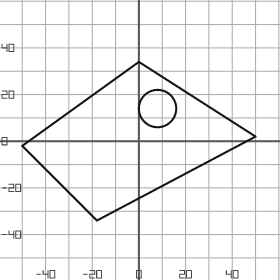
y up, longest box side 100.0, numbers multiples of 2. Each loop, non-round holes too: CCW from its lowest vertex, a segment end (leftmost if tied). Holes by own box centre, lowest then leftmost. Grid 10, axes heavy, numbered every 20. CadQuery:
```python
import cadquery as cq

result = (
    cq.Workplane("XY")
    .moveTo(-18.0, -34.0)
    .lineTo(50.0, 2.0)
    .lineTo(0.0, 34.0)
    .lineTo(-50.0, -2.0)
    .close()
    .moveTo(8.0, 14.0)
    .circle(8.0)
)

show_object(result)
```